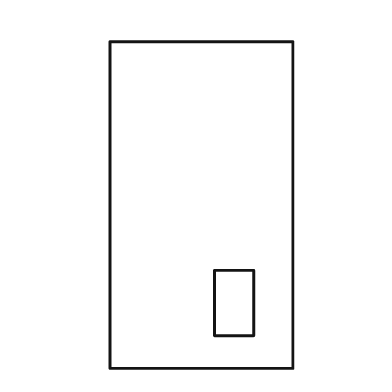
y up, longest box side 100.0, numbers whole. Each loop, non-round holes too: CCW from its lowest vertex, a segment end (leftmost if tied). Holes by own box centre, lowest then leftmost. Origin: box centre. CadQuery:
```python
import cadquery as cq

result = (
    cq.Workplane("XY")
    .moveTo(-28.0, -50.0)
    .lineTo(28.0, -50.0)
    .lineTo(28.0, 50.0)
    .lineTo(-28.0, 50.0)
    .close()
    .moveTo(4.0, -40.0)
    .lineTo(16.0, -40.0)
    .lineTo(16.0, -20.0)
    .lineTo(4.0, -20.0)
    .close()
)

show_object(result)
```